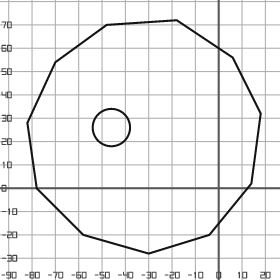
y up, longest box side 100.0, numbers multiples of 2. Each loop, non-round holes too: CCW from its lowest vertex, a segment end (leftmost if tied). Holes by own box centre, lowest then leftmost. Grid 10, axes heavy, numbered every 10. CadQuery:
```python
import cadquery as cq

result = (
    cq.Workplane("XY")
    .moveTo(-30.0, -28.0)
    .lineTo(-4.0, -20.0)
    .lineTo(14.0, 2.0)
    .lineTo(18.0, 32.0)
    .lineTo(6.0, 56.0)
    .lineTo(-18.0, 72.0)
    .lineTo(-48.0, 70.0)
    .lineTo(-70.0, 54.0)
    .lineTo(-82.0, 28.0)
    .lineTo(-78.0, 0.0)
    .lineTo(-58.0, -20.0)
    .close()
    .moveTo(-46.0, 26.0)
    .circle(8.0)
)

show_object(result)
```